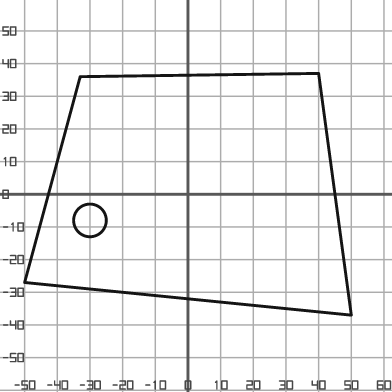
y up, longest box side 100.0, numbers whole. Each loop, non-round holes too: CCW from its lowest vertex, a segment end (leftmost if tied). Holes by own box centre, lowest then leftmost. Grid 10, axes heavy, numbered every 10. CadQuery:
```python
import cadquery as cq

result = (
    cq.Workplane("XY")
    .moveTo(50.0, -37.0)
    .lineTo(40.0, 37.0)
    .lineTo(-33.0, 36.0)
    .lineTo(-50.0, -27.0)
    .close()
    .moveTo(-30.0, -8.0)
    .circle(5.0)
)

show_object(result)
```